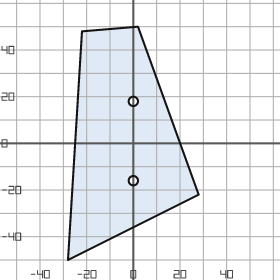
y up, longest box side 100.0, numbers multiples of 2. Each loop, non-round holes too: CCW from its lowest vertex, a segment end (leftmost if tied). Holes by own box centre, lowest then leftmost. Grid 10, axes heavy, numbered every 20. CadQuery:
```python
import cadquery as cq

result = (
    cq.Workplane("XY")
    .moveTo(-28.0, -50.0)
    .lineTo(28.0, -22.0)
    .lineTo(2.0, 50.0)
    .lineTo(-22.0, 48.0)
    .close()
    .moveTo(0.0, -16.0)
    .circle(2.0)
    .moveTo(0.0, 18.0)
    .circle(2.0)
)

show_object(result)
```